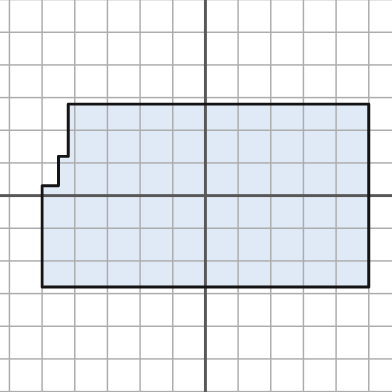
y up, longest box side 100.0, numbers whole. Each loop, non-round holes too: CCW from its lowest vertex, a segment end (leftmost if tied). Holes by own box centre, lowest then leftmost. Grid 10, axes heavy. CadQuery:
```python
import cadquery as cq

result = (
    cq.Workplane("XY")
    .moveTo(-50.0, -28.0)
    .lineTo(50.0, -28.0)
    .lineTo(50.0, 28.0)
    .lineTo(-42.0, 28.0)
    .lineTo(-42.0, 12.0)
    .lineTo(-45.0, 12.0)
    .lineTo(-45.0, 3.0)
    .lineTo(-50.0, 3.0)
    .close()
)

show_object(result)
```